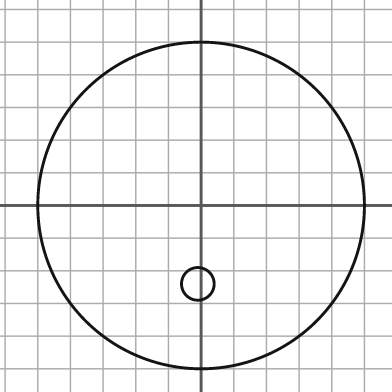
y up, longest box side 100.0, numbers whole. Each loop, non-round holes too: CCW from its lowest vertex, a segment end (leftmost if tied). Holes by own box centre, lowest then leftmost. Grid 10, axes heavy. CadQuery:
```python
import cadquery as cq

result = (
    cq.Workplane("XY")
    .moveTo(0.0, 0.0)
    .circle(50.0)
    .moveTo(-1.0, -24.0)
    .circle(5.0)
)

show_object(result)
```